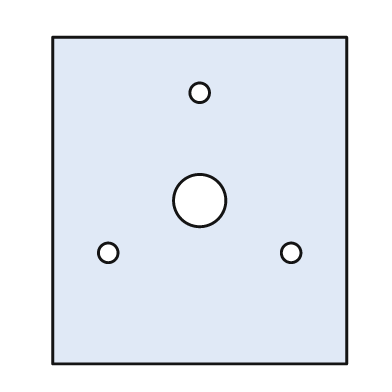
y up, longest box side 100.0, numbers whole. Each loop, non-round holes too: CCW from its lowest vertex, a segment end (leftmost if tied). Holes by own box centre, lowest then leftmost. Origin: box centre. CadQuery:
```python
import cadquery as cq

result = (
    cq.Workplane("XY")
    .moveTo(-45.0, -50.0)
    .lineTo(45.0, -50.0)
    .lineTo(45.0, 50.0)
    .lineTo(-45.0, 50.0)
    .close()
    .moveTo(-28.0, -16.0)
    .circle(3.0)
    .moveTo(28.0, -16.0)
    .circle(3.0)
    .moveTo(0.0, 0.0)
    .circle(8.0)
    .moveTo(0.0, 33.0)
    .circle(3.0)
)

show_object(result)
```